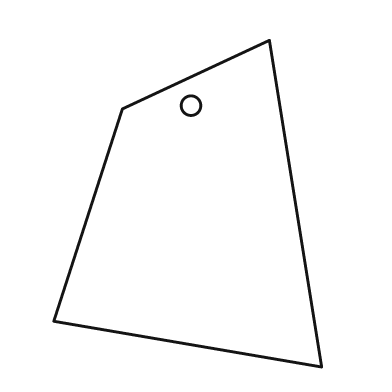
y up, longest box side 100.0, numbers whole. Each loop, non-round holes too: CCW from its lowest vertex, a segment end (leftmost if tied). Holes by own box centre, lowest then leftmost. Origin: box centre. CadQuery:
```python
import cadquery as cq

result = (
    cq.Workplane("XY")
    .moveTo(41.0, -50.0)
    .lineTo(25.0, 50.0)
    .lineTo(-20.0, 29.0)
    .lineTo(-41.0, -36.0)
    .close()
    .moveTo(1.0, 30.0)
    .circle(3.0)
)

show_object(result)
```